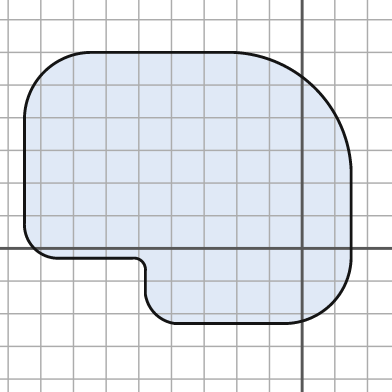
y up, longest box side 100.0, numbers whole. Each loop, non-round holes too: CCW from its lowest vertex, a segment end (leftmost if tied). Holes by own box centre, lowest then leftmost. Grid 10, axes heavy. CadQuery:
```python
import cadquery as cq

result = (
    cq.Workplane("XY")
    .moveTo(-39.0, -23.0)
    .lineTo(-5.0, -23.0)
    .threePointArc((9.0, -17.0), (15.0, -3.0))
    .lineTo(15.0, 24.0)
    .threePointArc((4.0, 49.0), (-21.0, 60.0))
    .lineTo(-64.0, 60.0)
    .threePointArc((-79.0, 54.0), (-85.0, 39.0))
    .lineTo(-85.0, 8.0)
    .threePointArc((-82.0, 0.0), (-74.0, -3.0))
    .lineTo(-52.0, -3.0)
    .threePointArc((-49.0, -4.0), (-48.0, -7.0))
    .lineTo(-48.0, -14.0)
    .threePointArc((-45.0, -20.0), (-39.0, -23.0))
    .close()
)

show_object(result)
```